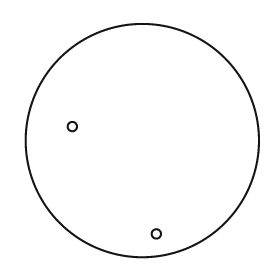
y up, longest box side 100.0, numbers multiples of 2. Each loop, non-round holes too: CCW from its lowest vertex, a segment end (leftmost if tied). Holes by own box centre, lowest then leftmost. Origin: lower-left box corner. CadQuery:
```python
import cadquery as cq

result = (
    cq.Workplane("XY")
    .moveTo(50.0, 50.0)
    .circle(50.0)
    .moveTo(56.0, 10.0)
    .circle(2.0)
    .moveTo(20.0, 56.0)
    .circle(2.0)
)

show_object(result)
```